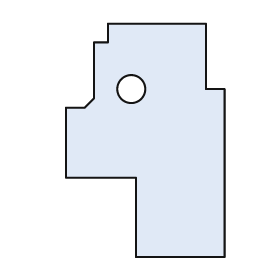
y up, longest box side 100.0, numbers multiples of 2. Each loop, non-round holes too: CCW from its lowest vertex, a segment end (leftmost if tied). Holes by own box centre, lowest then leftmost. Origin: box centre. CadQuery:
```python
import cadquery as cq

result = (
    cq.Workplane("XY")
    .moveTo(-4.0, -50.0)
    .lineTo(34.0, -50.0)
    .lineTo(34.0, 22.0)
    .lineTo(26.0, 22.0)
    .lineTo(26.0, 50.0)
    .lineTo(-16.0, 50.0)
    .lineTo(-16.0, 42.0)
    .lineTo(-22.0, 42.0)
    .lineTo(-22.0, 18.0)
    .lineTo(-26.0, 14.0)
    .lineTo(-34.0, 14.0)
    .lineTo(-34.0, -16.0)
    .lineTo(-4.0, -16.0)
    .close()
    .moveTo(-6.0, 22.0)
    .circle(6.0)
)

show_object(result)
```